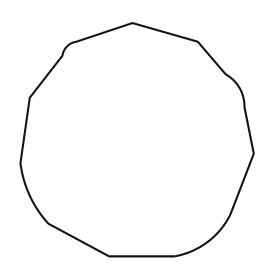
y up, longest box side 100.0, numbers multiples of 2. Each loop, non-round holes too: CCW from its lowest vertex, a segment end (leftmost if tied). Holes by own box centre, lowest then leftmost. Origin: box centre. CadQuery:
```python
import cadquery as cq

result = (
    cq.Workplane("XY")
    .moveTo(-12.0, -50.0)
    .lineTo(16.0, -50.0)
    .threePointArc((30.0, -44.0), (40.0, -32.0))
    .lineTo(50.0, -6.0)
    .lineTo(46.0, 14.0)
    .threePointArc((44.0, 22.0), (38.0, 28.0))
    .lineTo(26.0, 42.0)
    .lineTo(-2.0, 50.0)
    .lineTo(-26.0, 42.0)
    .threePointArc((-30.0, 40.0), (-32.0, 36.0))
    .lineTo(-46.0, 18.0)
    .lineTo(-50.0, -10.0)
    .threePointArc((-46.0, -24.0), (-38.0, -36.0))
    .close()
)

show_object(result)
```